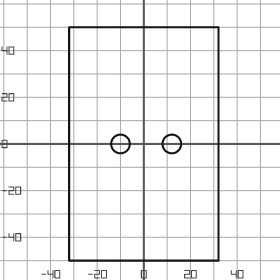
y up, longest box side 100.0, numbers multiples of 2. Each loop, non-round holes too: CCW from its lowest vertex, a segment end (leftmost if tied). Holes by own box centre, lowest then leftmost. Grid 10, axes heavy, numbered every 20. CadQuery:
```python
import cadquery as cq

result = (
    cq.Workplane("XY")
    .moveTo(-32.0, -50.0)
    .lineTo(32.0, -50.0)
    .lineTo(32.0, 50.0)
    .lineTo(-32.0, 50.0)
    .close()
    .moveTo(-10.0, 0.0)
    .circle(4.0)
    .moveTo(12.0, 0.0)
    .circle(4.0)
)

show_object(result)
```